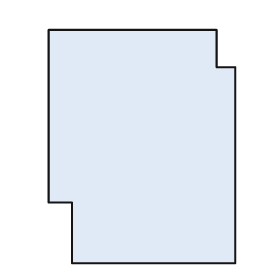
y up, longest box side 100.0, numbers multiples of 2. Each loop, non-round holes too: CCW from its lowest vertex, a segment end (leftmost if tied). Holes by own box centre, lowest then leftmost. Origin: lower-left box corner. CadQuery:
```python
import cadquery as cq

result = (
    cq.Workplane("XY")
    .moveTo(10.0, 0.0)
    .lineTo(80.0, 0.0)
    .lineTo(80.0, 84.0)
    .lineTo(72.0, 84.0)
    .lineTo(72.0, 100.0)
    .lineTo(0.0, 100.0)
    .lineTo(0.0, 26.0)
    .lineTo(10.0, 26.0)
    .close()
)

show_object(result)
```